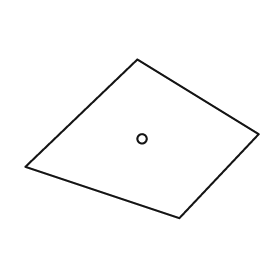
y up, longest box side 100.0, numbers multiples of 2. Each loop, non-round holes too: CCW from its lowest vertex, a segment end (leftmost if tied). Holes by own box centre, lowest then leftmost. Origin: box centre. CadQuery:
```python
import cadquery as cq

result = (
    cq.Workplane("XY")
    .moveTo(16.0, -34.0)
    .lineTo(50.0, 2.0)
    .lineTo(-2.0, 34.0)
    .lineTo(-50.0, -12.0)
    .close()
    .moveTo(0.0, 0.0)
    .circle(2.0)
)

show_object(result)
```